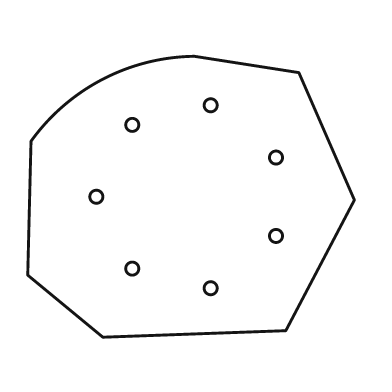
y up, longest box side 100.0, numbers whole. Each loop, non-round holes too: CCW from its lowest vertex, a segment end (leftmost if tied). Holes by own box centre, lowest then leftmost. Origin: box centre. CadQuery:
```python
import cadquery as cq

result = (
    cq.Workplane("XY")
    .moveTo(-27.0, -43.0)
    .lineTo(29.0, -41.0)
    .lineTo(50.0, -1.0)
    .lineTo(33.0, 38.0)
    .lineTo(1.0, 43.0)
    .threePointArc((-27.0, 36.0), (-49.0, 17.0))
    .lineTo(-50.0, -24.0)
    .close()
    .moveTo(6.0, -28.0)
    .circle(2.0)
    .moveTo(-18.0, -22.0)
    .circle(2.0)
    .moveTo(26.0, -12.0)
    .circle(2.0)
    .moveTo(-29.0, 0.0)
    .circle(2.0)
    .moveTo(26.0, 12.0)
    .circle(2.0)
    .moveTo(-18.0, 22.0)
    .circle(2.0)
    .moveTo(6.0, 28.0)
    .circle(2.0)
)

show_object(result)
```